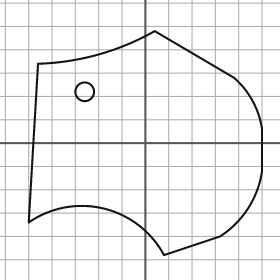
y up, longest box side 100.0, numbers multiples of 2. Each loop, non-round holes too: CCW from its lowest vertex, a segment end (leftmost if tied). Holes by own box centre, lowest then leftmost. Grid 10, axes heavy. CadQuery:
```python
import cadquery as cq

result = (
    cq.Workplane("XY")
    .moveTo(8.0, -48.0)
    .lineTo(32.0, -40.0)
    .threePointArc((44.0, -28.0), (50.0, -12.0))
    .lineTo(50.0, 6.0)
    .threePointArc((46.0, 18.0), (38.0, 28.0))
    .lineTo(4.0, 48.0)
    .threePointArc((-20.0, 38.0), (-46.0, 34.0))
    .lineTo(-50.0, -34.0)
    .threePointArc((-18.0, -28.0), (8.0, -48.0))
    .close()
    .moveTo(-26.0, 22.0)
    .circle(4.0)
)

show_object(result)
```